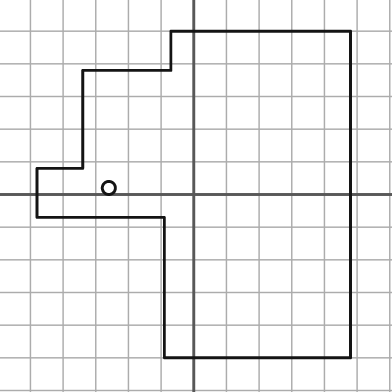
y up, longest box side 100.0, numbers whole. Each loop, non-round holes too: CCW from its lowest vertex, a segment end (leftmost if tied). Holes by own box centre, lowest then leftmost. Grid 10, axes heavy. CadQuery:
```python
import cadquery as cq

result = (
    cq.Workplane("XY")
    .moveTo(-9.0, -50.0)
    .lineTo(48.0, -50.0)
    .lineTo(48.0, 50.0)
    .lineTo(-7.0, 50.0)
    .lineTo(-7.0, 38.0)
    .lineTo(-34.0, 38.0)
    .lineTo(-34.0, 8.0)
    .lineTo(-48.0, 8.0)
    .lineTo(-48.0, -7.0)
    .lineTo(-9.0, -7.0)
    .close()
    .moveTo(-26.0, 2.0)
    .circle(2.0)
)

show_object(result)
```